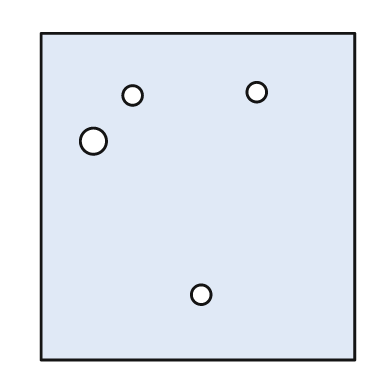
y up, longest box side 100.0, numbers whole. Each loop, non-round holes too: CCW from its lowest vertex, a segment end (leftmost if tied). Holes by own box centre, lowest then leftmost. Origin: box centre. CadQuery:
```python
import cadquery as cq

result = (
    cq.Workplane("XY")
    .moveTo(-48.0, -50.0)
    .lineTo(48.0, -50.0)
    .lineTo(48.0, 50.0)
    .lineTo(-48.0, 50.0)
    .close()
    .moveTo(1.0, -30.0)
    .circle(3.0)
    .moveTo(-32.0, 17.0)
    .circle(4.0)
    .moveTo(-20.0, 31.0)
    .circle(3.0)
    .moveTo(18.0, 32.0)
    .circle(3.0)
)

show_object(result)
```